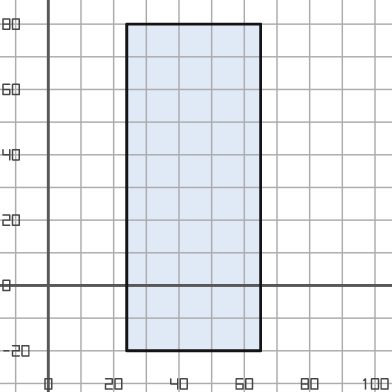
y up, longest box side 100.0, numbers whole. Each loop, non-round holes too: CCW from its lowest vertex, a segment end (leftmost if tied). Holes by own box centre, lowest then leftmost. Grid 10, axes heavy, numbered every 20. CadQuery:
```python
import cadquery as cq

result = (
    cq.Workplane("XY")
    .moveTo(24.0, -20.0)
    .lineTo(65.0, -20.0)
    .lineTo(65.0, 80.0)
    .lineTo(24.0, 80.0)
    .close()
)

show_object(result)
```